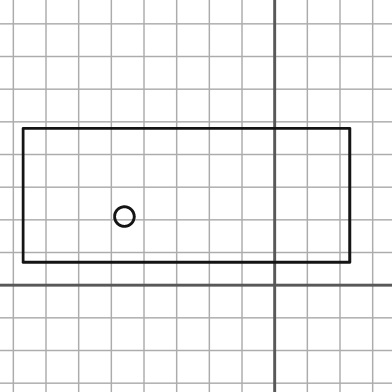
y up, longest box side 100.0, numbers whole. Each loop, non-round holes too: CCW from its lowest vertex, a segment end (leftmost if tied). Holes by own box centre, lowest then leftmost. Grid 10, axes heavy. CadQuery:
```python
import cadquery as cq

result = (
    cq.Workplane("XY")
    .moveTo(-77.0, 7.0)
    .lineTo(23.0, 7.0)
    .lineTo(23.0, 48.0)
    .lineTo(-77.0, 48.0)
    .close()
    .moveTo(-46.0, 21.0)
    .circle(3.0)
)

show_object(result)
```